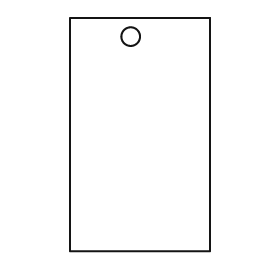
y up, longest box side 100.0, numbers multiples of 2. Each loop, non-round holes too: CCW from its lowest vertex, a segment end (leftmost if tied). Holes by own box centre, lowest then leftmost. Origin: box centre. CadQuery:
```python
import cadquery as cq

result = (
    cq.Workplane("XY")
    .moveTo(-30.0, -50.0)
    .lineTo(30.0, -50.0)
    .lineTo(30.0, 50.0)
    .lineTo(-30.0, 50.0)
    .close()
    .moveTo(-4.0, 42.0)
    .circle(4.0)
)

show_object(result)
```